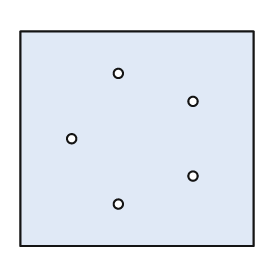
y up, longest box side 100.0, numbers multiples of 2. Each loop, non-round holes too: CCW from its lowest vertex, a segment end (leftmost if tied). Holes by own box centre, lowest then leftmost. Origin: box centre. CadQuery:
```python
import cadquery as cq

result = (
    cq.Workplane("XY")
    .moveTo(-50.0, -46.0)
    .lineTo(50.0, -46.0)
    .lineTo(50.0, 46.0)
    .lineTo(-50.0, 46.0)
    .close()
    .moveTo(-8.0, -28.0)
    .circle(2.0)
    .moveTo(24.0, -16.0)
    .circle(2.0)
    .moveTo(-28.0, 0.0)
    .circle(2.0)
    .moveTo(24.0, 16.0)
    .circle(2.0)
    .moveTo(-8.0, 28.0)
    .circle(2.0)
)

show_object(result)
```